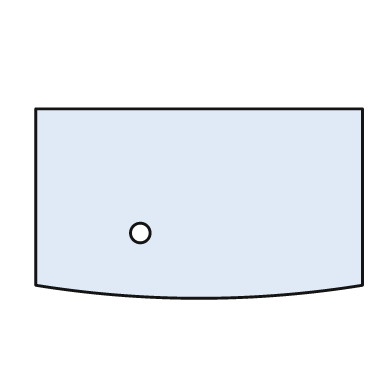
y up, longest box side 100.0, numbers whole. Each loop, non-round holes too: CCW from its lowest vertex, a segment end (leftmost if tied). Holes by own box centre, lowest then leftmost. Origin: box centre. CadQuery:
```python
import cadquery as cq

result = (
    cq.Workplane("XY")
    .moveTo(-50.0, -25.0)
    .threePointArc((0.0, -29.0), (50.0, -25.0))
    .lineTo(50.0, 29.0)
    .lineTo(-50.0, 29.0)
    .close()
    .moveTo(-18.0, -9.0)
    .circle(3.0)
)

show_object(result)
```